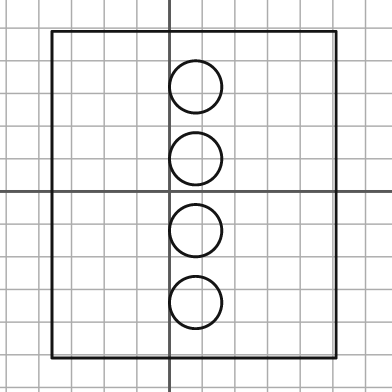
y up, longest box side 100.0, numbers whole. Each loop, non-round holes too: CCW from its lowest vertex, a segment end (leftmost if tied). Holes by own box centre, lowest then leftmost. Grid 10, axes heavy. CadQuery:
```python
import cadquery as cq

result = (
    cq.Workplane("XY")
    .moveTo(-36.0, -51.0)
    .lineTo(51.0, -51.0)
    .lineTo(51.0, 49.0)
    .lineTo(-36.0, 49.0)
    .close()
    .moveTo(8.0, -34.0)
    .circle(8.0)
    .moveTo(8.0, -12.0)
    .circle(8.0)
    .moveTo(8.0, 10.0)
    .circle(8.0)
    .moveTo(8.0, 32.0)
    .circle(8.0)
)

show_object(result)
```